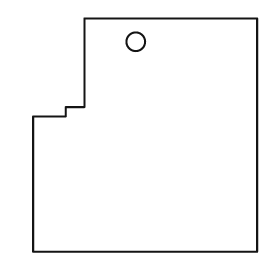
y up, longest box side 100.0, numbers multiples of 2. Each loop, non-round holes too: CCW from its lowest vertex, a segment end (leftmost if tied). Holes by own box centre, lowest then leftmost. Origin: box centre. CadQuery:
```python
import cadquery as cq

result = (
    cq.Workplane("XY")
    .moveTo(-48.0, -50.0)
    .lineTo(48.0, -50.0)
    .lineTo(48.0, 50.0)
    .lineTo(-26.0, 50.0)
    .lineTo(-26.0, 12.0)
    .lineTo(-34.0, 12.0)
    .lineTo(-34.0, 8.0)
    .lineTo(-48.0, 8.0)
    .close()
    .moveTo(-4.0, 40.0)
    .circle(4.0)
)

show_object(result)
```